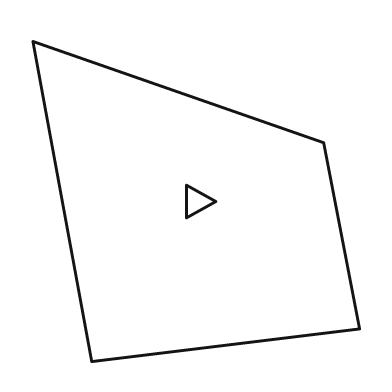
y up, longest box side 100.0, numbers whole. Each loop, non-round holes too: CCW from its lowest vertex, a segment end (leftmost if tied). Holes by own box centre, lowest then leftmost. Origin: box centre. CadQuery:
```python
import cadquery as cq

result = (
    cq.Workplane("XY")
    .moveTo(-32.0, -49.0)
    .lineTo(50.0, -39.0)
    .lineTo(39.0, 18.0)
    .lineTo(-50.0, 49.0)
    .close()
    .moveTo(-3.0, -5.0)
    .lineTo(6.0, 0.0)
    .lineTo(-3.0, 5.0)
    .close()
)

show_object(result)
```